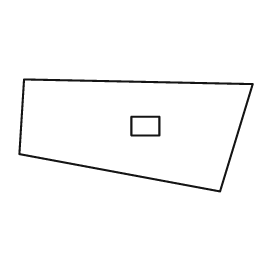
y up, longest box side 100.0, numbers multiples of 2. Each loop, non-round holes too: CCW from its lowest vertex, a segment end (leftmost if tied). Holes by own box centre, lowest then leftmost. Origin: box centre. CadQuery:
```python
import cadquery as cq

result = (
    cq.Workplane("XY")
    .moveTo(36.0, -24.0)
    .lineTo(50.0, 22.0)
    .lineTo(-48.0, 24.0)
    .lineTo(-50.0, -8.0)
    .close()
    .moveTo(-2.0, 0.0)
    .lineTo(10.0, 0.0)
    .lineTo(10.0, 8.0)
    .lineTo(-2.0, 8.0)
    .close()
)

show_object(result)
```